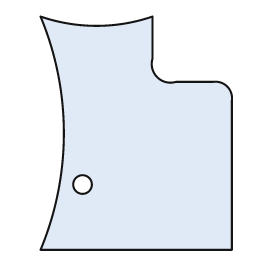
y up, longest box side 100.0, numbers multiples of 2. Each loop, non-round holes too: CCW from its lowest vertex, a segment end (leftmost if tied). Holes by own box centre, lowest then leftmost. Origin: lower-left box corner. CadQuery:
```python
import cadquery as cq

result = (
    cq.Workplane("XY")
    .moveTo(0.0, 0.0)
    .lineTo(82.0, 0.0)
    .lineTo(82.0, 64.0)
    .threePointArc((80.0, 70.0), (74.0, 72.0))
    .lineTo(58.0, 72.0)
    .threePointArc((50.0, 74.0), (48.0, 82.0))
    .lineTo(48.0, 100.0)
    .threePointArc((24.0, 96.0), (0.0, 100.0))
    .threePointArc((10.0, 50.0), (0.0, 0.0))
    .close()
    .moveTo(18.0, 28.0)
    .circle(4.0)
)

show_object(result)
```